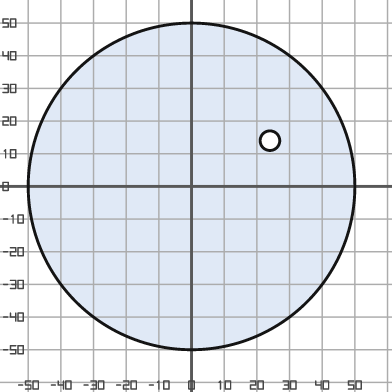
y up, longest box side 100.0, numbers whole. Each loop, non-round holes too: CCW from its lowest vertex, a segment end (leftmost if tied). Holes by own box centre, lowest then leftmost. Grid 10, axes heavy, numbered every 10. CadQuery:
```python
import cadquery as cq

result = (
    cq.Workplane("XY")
    .moveTo(0.0, 0.0)
    .circle(50.0)
    .moveTo(24.0, 14.0)
    .circle(3.0)
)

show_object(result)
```